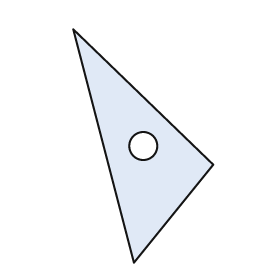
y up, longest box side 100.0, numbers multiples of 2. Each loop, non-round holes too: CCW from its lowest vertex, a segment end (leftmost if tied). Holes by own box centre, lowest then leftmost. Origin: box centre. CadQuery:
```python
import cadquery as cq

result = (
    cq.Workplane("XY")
    .moveTo(-4.0, -50.0)
    .lineTo(30.0, -8.0)
    .lineTo(-30.0, 50.0)
    .close()
    .moveTo(0.0, 0.0)
    .circle(6.0)
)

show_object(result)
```